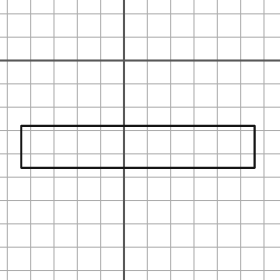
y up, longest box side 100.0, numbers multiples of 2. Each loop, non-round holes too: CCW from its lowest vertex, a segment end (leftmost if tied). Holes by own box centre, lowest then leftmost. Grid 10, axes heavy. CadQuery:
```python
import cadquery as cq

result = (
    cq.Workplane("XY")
    .moveTo(-44.0, -46.0)
    .lineTo(56.0, -46.0)
    .lineTo(56.0, -28.0)
    .lineTo(-44.0, -28.0)
    .close()
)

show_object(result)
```